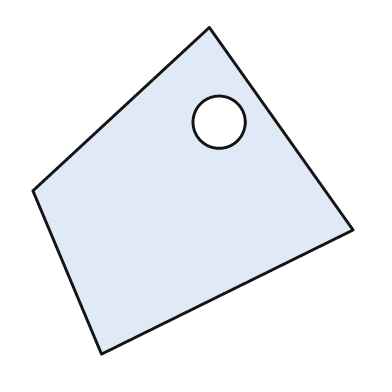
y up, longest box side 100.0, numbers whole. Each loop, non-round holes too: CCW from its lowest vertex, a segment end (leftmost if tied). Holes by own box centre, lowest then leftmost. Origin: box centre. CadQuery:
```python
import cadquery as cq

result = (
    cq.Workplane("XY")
    .moveTo(-28.0, -50.0)
    .lineTo(49.0, -12.0)
    .lineTo(5.0, 50.0)
    .lineTo(-49.0, 0.0)
    .close()
    .moveTo(8.0, 21.0)
    .circle(8.0)
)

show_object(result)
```